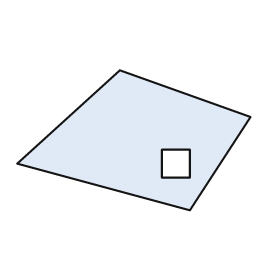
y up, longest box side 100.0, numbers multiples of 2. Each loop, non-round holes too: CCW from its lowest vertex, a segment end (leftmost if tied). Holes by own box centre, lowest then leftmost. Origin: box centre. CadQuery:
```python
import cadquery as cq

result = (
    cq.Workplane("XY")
    .moveTo(24.0, -30.0)
    .lineTo(50.0, 10.0)
    .lineTo(-6.0, 30.0)
    .lineTo(-50.0, -10.0)
    .close()
    .moveTo(12.0, -16.0)
    .lineTo(24.0, -16.0)
    .lineTo(24.0, -4.0)
    .lineTo(12.0, -4.0)
    .close()
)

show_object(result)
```